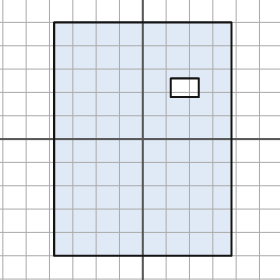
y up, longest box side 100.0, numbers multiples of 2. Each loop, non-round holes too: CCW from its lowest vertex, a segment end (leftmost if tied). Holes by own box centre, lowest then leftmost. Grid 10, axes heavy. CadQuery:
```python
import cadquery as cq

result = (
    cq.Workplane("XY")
    .moveTo(-38.0, -50.0)
    .lineTo(38.0, -50.0)
    .lineTo(38.0, 50.0)
    .lineTo(-38.0, 50.0)
    .close()
    .moveTo(12.0, 18.0)
    .lineTo(24.0, 18.0)
    .lineTo(24.0, 26.0)
    .lineTo(12.0, 26.0)
    .close()
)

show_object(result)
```